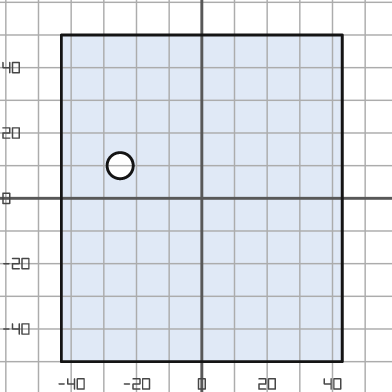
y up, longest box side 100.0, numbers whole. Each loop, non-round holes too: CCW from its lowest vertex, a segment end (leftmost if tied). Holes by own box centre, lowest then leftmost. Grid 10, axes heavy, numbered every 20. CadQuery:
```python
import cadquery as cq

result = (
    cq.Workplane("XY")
    .moveTo(-43.0, -50.0)
    .lineTo(43.0, -50.0)
    .lineTo(43.0, 50.0)
    .lineTo(-43.0, 50.0)
    .close()
    .moveTo(-25.0, 10.0)
    .circle(4.0)
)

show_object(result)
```